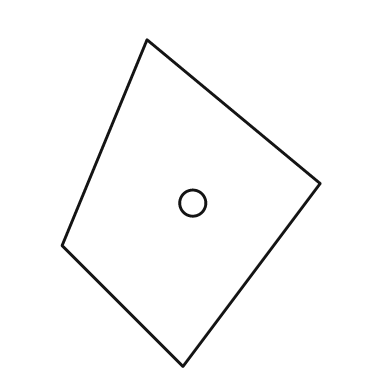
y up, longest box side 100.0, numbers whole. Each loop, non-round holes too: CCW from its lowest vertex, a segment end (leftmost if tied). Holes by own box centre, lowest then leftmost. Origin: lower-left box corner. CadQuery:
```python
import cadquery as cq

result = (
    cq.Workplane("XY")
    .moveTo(37.0, 0.0)
    .lineTo(79.0, 56.0)
    .lineTo(26.0, 100.0)
    .lineTo(0.0, 37.0)
    .close()
    .moveTo(40.0, 50.0)
    .circle(4.0)
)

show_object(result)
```